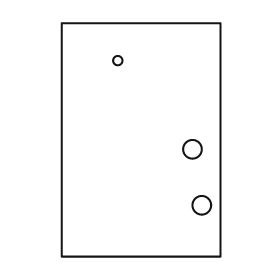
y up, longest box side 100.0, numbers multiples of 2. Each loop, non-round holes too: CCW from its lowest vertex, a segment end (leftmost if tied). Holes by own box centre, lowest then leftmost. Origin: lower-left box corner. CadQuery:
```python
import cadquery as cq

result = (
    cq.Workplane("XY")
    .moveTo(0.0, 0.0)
    .lineTo(68.0, 0.0)
    .lineTo(68.0, 100.0)
    .lineTo(0.0, 100.0)
    .close()
    .moveTo(60.0, 22.0)
    .circle(4.0)
    .moveTo(56.0, 46.0)
    .circle(4.0)
    .moveTo(24.0, 84.0)
    .circle(2.0)
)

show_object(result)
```